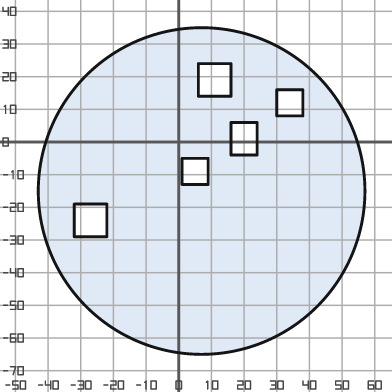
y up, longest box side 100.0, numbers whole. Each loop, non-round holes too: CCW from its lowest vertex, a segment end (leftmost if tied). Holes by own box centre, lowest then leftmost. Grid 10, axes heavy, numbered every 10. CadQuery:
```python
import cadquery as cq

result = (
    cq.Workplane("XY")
    .moveTo(7.0, -15.0)
    .circle(50.0)
    .moveTo(-32.0, -29.0)
    .lineTo(-22.0, -29.0)
    .lineTo(-22.0, -19.0)
    .lineTo(-32.0, -19.0)
    .close()
    .moveTo(1.0, -13.0)
    .lineTo(9.0, -13.0)
    .lineTo(9.0, -5.0)
    .lineTo(1.0, -5.0)
    .close()
    .moveTo(16.0, -4.0)
    .lineTo(24.0, -4.0)
    .lineTo(24.0, 6.0)
    .lineTo(16.0, 6.0)
    .close()
    .moveTo(30.0, 8.0)
    .lineTo(38.0, 8.0)
    .lineTo(38.0, 16.0)
    .lineTo(30.0, 16.0)
    .close()
    .moveTo(6.0, 14.0)
    .lineTo(16.0, 14.0)
    .lineTo(16.0, 24.0)
    .lineTo(6.0, 24.0)
    .close()
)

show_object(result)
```